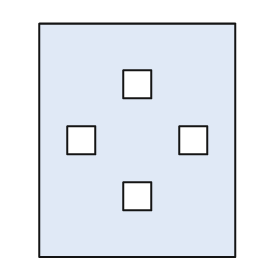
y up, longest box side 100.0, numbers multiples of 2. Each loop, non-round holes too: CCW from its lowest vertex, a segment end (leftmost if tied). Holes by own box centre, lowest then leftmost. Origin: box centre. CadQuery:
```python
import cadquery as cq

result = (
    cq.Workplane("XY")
    .moveTo(-42.0, -50.0)
    .lineTo(42.0, -50.0)
    .lineTo(42.0, 50.0)
    .lineTo(-42.0, 50.0)
    .close()
    .moveTo(-6.0, -30.0)
    .lineTo(6.0, -30.0)
    .lineTo(6.0, -18.0)
    .lineTo(-6.0, -18.0)
    .close()
    .moveTo(-30.0, -6.0)
    .lineTo(-18.0, -6.0)
    .lineTo(-18.0, 6.0)
    .lineTo(-30.0, 6.0)
    .close()
    .moveTo(18.0, -6.0)
    .lineTo(30.0, -6.0)
    .lineTo(30.0, 6.0)
    .lineTo(18.0, 6.0)
    .close()
    .moveTo(-6.0, 18.0)
    .lineTo(6.0, 18.0)
    .lineTo(6.0, 30.0)
    .lineTo(-6.0, 30.0)
    .close()
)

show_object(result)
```